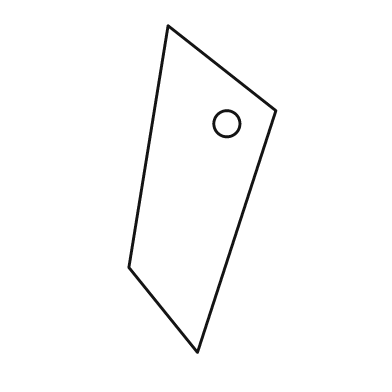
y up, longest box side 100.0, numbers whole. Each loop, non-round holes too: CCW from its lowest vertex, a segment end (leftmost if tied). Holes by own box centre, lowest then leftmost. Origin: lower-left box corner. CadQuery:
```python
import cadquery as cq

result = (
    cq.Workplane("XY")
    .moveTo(21.0, 0.0)
    .lineTo(45.0, 74.0)
    .lineTo(12.0, 100.0)
    .lineTo(0.0, 26.0)
    .close()
    .moveTo(30.0, 70.0)
    .circle(4.0)
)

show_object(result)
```